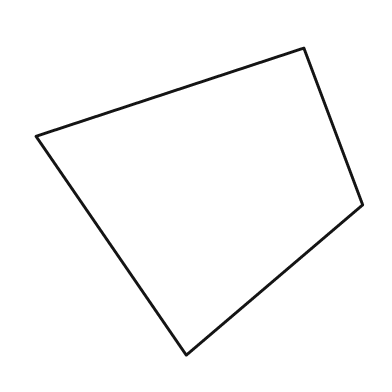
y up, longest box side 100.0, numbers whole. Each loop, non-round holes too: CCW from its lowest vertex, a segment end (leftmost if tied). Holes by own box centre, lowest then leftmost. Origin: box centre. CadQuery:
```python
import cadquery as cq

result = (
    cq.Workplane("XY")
    .moveTo(-4.0, -47.0)
    .lineTo(50.0, -1.0)
    .lineTo(32.0, 47.0)
    .lineTo(-50.0, 20.0)
    .close()
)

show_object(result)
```